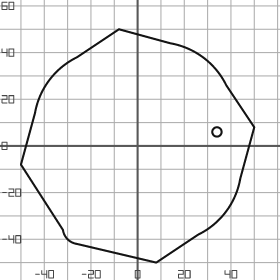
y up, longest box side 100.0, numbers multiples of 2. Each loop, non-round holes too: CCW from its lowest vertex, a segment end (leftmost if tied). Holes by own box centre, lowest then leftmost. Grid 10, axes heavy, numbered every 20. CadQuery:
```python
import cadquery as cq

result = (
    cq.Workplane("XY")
    .moveTo(8.0, -50.0)
    .lineTo(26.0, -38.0)
    .threePointArc((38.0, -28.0), (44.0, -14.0))
    .lineTo(50.0, 8.0)
    .lineTo(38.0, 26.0)
    .threePointArc((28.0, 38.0), (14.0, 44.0))
    .lineTo(-8.0, 50.0)
    .lineTo(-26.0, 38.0)
    .threePointArc((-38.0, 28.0), (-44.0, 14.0))
    .lineTo(-50.0, -8.0)
    .lineTo(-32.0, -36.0)
    .threePointArc((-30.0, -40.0), (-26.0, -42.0))
    .close()
    .moveTo(34.0, 6.0)
    .circle(2.0)
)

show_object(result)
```